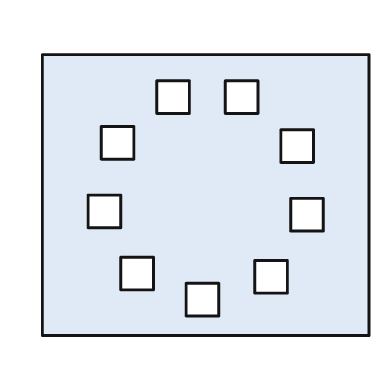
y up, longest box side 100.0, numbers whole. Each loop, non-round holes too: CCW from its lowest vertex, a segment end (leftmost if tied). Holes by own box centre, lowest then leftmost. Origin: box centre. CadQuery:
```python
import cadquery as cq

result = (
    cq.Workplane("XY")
    .moveTo(-50.0, -43.0)
    .lineTo(50.0, -43.0)
    .lineTo(50.0, 43.0)
    .lineTo(-50.0, 43.0)
    .close()
    .moveTo(-6.0, -37.0)
    .lineTo(4.0, -37.0)
    .lineTo(4.0, -27.0)
    .lineTo(-6.0, -27.0)
    .close()
    .moveTo(15.0, -30.0)
    .lineTo(25.0, -30.0)
    .lineTo(25.0, -20.0)
    .lineTo(15.0, -20.0)
    .close()
    .moveTo(-26.0, -29.0)
    .lineTo(-16.0, -29.0)
    .lineTo(-16.0, -19.0)
    .lineTo(-26.0, -19.0)
    .close()
    .moveTo(26.0, -11.0)
    .lineTo(36.0, -11.0)
    .lineTo(36.0, -1.0)
    .lineTo(26.0, -1.0)
    .close()
    .moveTo(-36.0, -10.0)
    .lineTo(-26.0, -10.0)
    .lineTo(-26.0, 0.0)
    .lineTo(-36.0, 0.0)
    .close()
    .moveTo(23.0, 10.0)
    .lineTo(33.0, 10.0)
    .lineTo(33.0, 20.0)
    .lineTo(23.0, 20.0)
    .close()
    .moveTo(-32.0, 11.0)
    .lineTo(-22.0, 11.0)
    .lineTo(-22.0, 21.0)
    .lineTo(-32.0, 21.0)
    .close()
    .moveTo(-15.0, 25.0)
    .lineTo(-5.0, 25.0)
    .lineTo(-5.0, 35.0)
    .lineTo(-15.0, 35.0)
    .close()
    .moveTo(6.0, 25.0)
    .lineTo(16.0, 25.0)
    .lineTo(16.0, 35.0)
    .lineTo(6.0, 35.0)
    .close()
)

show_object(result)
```